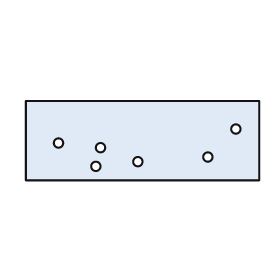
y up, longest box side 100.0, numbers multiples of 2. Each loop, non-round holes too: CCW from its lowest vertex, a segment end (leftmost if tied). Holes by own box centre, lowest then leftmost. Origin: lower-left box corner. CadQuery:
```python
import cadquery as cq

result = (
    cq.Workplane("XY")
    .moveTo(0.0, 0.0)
    .lineTo(100.0, 0.0)
    .lineTo(100.0, 34.0)
    .lineTo(0.0, 34.0)
    .close()
    .moveTo(30.0, 6.0)
    .circle(2.0)
    .moveTo(48.0, 8.0)
    .circle(2.0)
    .moveTo(78.0, 10.0)
    .circle(2.0)
    .moveTo(32.0, 14.0)
    .circle(2.0)
    .moveTo(14.0, 16.0)
    .circle(2.0)
    .moveTo(90.0, 22.0)
    .circle(2.0)
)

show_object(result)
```